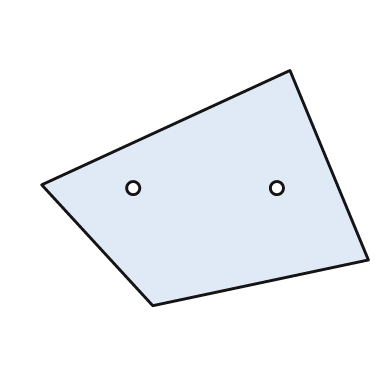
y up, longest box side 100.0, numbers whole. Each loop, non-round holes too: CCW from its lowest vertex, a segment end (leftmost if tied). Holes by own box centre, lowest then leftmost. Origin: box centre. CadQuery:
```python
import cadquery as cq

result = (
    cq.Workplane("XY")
    .moveTo(-16.0, -36.0)
    .lineTo(50.0, -22.0)
    .lineTo(26.0, 36.0)
    .lineTo(-50.0, 1.0)
    .close()
    .moveTo(-22.0, 0.0)
    .circle(2.0)
    .moveTo(22.0, 0.0)
    .circle(2.0)
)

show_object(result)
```